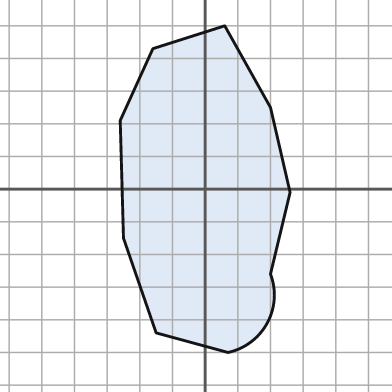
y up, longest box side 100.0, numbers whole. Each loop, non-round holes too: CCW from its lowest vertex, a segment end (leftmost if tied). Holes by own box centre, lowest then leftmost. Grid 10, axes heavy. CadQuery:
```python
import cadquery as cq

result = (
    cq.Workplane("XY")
    .moveTo(7.0, -50.0)
    .threePointArc((19.0, -41.0), (20.0, -26.0))
    .lineTo(26.0, -1.0)
    .lineTo(20.0, 25.0)
    .lineTo(6.0, 50.0)
    .lineTo(-16.0, 43.0)
    .lineTo(-26.0, 21.0)
    .lineTo(-25.0, -15.0)
    .lineTo(-15.0, -44.0)
    .close()
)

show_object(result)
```